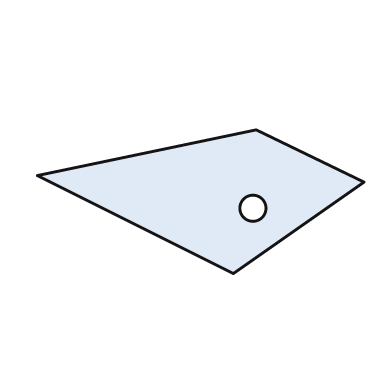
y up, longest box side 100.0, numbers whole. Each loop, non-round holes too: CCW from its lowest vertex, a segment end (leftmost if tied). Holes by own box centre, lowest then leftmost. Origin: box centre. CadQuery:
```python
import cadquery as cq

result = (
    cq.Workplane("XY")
    .moveTo(10.0, -22.0)
    .lineTo(50.0, 6.0)
    .lineTo(17.0, 22.0)
    .lineTo(-50.0, 8.0)
    .close()
    .moveTo(16.0, -2.0)
    .circle(4.0)
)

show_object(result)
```